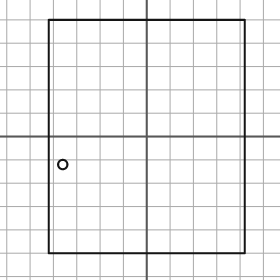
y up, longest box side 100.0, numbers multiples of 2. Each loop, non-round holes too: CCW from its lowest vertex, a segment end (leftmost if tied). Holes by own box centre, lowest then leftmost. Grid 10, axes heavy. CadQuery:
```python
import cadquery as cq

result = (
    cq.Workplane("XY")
    .moveTo(-42.0, -50.0)
    .lineTo(42.0, -50.0)
    .lineTo(42.0, 50.0)
    .lineTo(-42.0, 50.0)
    .close()
    .moveTo(-36.0, -12.0)
    .circle(2.0)
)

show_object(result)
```